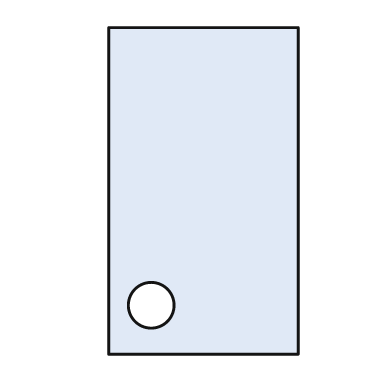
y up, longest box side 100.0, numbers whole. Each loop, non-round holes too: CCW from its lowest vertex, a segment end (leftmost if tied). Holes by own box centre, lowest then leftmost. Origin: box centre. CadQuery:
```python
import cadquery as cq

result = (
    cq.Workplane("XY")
    .moveTo(-29.0, -50.0)
    .lineTo(29.0, -50.0)
    .lineTo(29.0, 50.0)
    .lineTo(-29.0, 50.0)
    .close()
    .moveTo(-16.0, -35.0)
    .circle(7.0)
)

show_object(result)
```